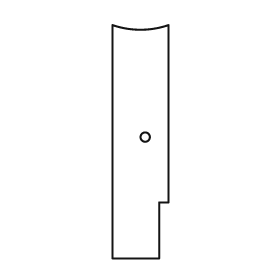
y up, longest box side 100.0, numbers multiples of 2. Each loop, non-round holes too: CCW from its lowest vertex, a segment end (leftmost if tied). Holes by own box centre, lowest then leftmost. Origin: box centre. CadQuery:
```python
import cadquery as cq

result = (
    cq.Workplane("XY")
    .moveTo(-12.0, -50.0)
    .lineTo(8.0, -50.0)
    .lineTo(8.0, -26.0)
    .lineTo(12.0, -26.0)
    .lineTo(12.0, 50.0)
    .threePointArc((0.0, 48.0), (-12.0, 50.0))
    .close()
    .moveTo(2.0, 2.0)
    .circle(2.0)
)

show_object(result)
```